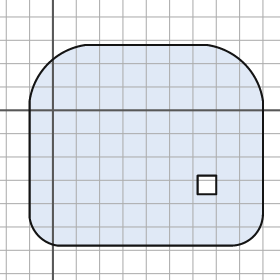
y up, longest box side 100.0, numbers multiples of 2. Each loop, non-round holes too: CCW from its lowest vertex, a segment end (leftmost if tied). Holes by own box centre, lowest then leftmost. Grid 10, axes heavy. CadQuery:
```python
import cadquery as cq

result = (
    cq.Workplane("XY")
    .moveTo(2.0, -58.0)
    .lineTo(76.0, -58.0)
    .threePointArc((86.0, -54.0), (90.0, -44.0))
    .lineTo(90.0, 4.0)
    .threePointArc((82.0, 20.0), (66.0, 28.0))
    .lineTo(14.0, 28.0)
    .threePointArc((-2.0, 20.0), (-10.0, 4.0))
    .lineTo(-10.0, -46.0)
    .threePointArc((-6.0, -54.0), (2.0, -58.0))
    .close()
    .moveTo(62.0, -36.0)
    .lineTo(70.0, -36.0)
    .lineTo(70.0, -28.0)
    .lineTo(62.0, -28.0)
    .close()
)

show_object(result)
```